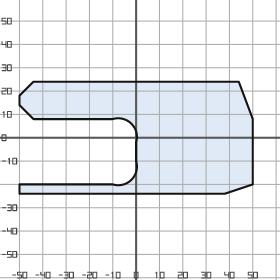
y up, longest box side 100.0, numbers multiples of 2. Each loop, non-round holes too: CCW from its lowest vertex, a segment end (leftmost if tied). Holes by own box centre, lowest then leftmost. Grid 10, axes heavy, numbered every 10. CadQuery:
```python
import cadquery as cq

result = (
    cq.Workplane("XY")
    .moveTo(-50.0, -24.0)
    .lineTo(38.0, -24.0)
    .lineTo(50.0, -20.0)
    .lineTo(50.0, 8.0)
    .lineTo(44.0, 24.0)
    .lineTo(-44.0, 24.0)
    .lineTo(-50.0, 18.0)
    .lineTo(-50.0, 14.0)
    .lineTo(-44.0, 8.0)
    .lineTo(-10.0, 8.0)
    .threePointArc((-2.0, 6.0), (0.0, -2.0))
    .lineTo(0.0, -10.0)
    .threePointArc((-2.0, -18.0), (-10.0, -20.0))
    .lineTo(-50.0, -20.0)
    .close()
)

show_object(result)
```